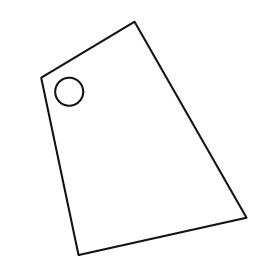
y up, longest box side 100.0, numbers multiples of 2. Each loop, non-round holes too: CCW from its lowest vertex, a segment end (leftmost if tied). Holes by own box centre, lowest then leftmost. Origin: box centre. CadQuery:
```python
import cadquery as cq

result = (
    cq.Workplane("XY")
    .moveTo(-28.0, -50.0)
    .lineTo(44.0, -34.0)
    .lineTo(-4.0, 50.0)
    .lineTo(-44.0, 26.0)
    .close()
    .moveTo(-32.0, 20.0)
    .circle(6.0)
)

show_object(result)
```